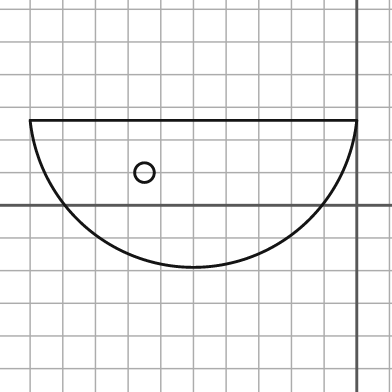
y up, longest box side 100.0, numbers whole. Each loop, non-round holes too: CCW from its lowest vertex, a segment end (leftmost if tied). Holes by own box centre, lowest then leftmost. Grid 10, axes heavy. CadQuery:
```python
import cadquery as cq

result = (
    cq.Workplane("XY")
    .moveTo(-100.0, 26.0)
    .threePointArc((-50.0, -19.0), (0.0, 26.0))
    .close()
    .moveTo(-65.0, 10.0)
    .circle(3.0)
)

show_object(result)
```